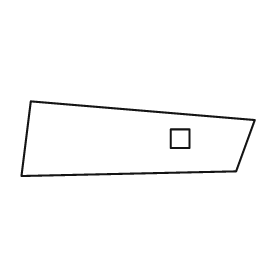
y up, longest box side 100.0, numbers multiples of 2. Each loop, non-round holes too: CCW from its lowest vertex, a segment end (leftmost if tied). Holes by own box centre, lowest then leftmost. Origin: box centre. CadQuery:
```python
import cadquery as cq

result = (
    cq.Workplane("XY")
    .moveTo(-50.0, -16.0)
    .lineTo(42.0, -14.0)
    .lineTo(50.0, 8.0)
    .lineTo(-46.0, 16.0)
    .close()
    .moveTo(14.0, -4.0)
    .lineTo(22.0, -4.0)
    .lineTo(22.0, 4.0)
    .lineTo(14.0, 4.0)
    .close()
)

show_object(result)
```